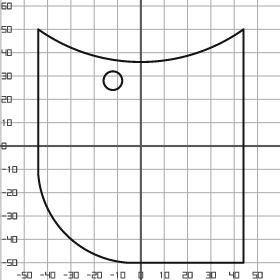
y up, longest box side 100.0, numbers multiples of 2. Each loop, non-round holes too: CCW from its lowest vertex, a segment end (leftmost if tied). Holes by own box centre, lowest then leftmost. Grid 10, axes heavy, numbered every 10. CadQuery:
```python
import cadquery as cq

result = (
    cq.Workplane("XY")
    .moveTo(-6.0, -50.0)
    .lineTo(44.0, -50.0)
    .lineTo(44.0, 50.0)
    .threePointArc((0.0, 36.0), (-44.0, 50.0))
    .lineTo(-44.0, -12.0)
    .threePointArc((-32.0, -38.0), (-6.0, -50.0))
    .close()
    .moveTo(-12.0, 28.0)
    .circle(4.0)
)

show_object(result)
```